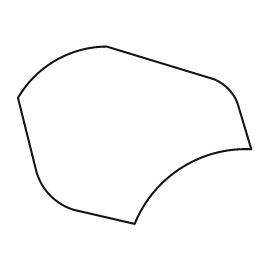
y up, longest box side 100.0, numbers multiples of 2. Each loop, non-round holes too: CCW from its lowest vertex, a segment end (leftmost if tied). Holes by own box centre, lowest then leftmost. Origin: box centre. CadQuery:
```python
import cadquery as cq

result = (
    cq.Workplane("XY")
    .moveTo(0.0, -38.0)
    .threePointArc((20.0, -14.0), (50.0, -6.0))
    .lineTo(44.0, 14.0)
    .threePointArc((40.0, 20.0), (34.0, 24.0))
    .lineTo(-12.0, 38.0)
    .threePointArc((-34.0, 32.0), (-50.0, 16.0))
    .lineTo(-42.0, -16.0)
    .threePointArc((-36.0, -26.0), (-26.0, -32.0))
    .close()
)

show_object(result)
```